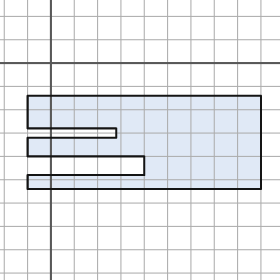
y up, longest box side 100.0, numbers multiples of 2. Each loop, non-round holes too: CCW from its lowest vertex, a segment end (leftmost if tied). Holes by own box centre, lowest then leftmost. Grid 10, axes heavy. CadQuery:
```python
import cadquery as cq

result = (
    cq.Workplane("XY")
    .moveTo(-10.0, -54.0)
    .lineTo(90.0, -54.0)
    .lineTo(90.0, -14.0)
    .lineTo(-10.0, -14.0)
    .lineTo(-10.0, -28.0)
    .lineTo(28.0, -28.0)
    .lineTo(28.0, -32.0)
    .lineTo(-10.0, -32.0)
    .lineTo(-10.0, -40.0)
    .lineTo(40.0, -40.0)
    .lineTo(40.0, -48.0)
    .lineTo(-10.0, -48.0)
    .close()
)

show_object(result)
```